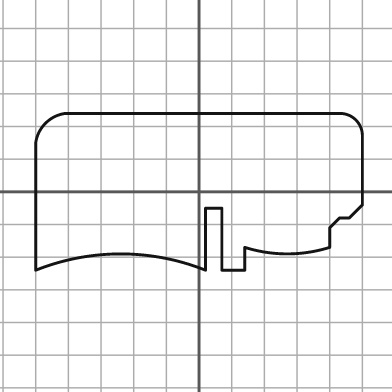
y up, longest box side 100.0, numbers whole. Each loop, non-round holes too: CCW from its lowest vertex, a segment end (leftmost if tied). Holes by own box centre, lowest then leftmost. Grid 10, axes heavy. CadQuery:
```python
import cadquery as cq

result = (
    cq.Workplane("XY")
    .moveTo(-50.0, -24.0)
    .threePointArc((-24.0, -19.0), (2.0, -24.0))
    .lineTo(2.0, -5.0)
    .lineTo(7.0, -5.0)
    .lineTo(7.0, -24.0)
    .lineTo(14.0, -24.0)
    .lineTo(14.0, -17.0)
    .threePointArc((27.0, -19.0), (40.0, -17.0))
    .lineTo(40.0, -11.0)
    .lineTo(43.0, -8.0)
    .lineTo(46.0, -8.0)
    .lineTo(50.0, -4.0)
    .lineTo(50.0, 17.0)
    .threePointArc((48.0, 22.0), (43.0, 24.0))
    .lineTo(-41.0, 24.0)
    .threePointArc((-47.0, 21.0), (-50.0, 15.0))
    .close()
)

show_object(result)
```